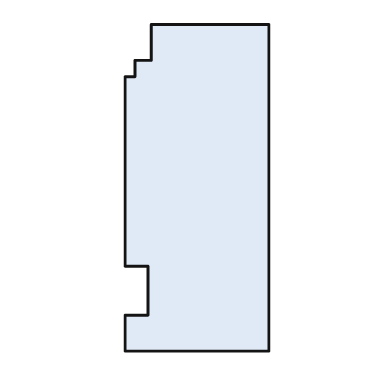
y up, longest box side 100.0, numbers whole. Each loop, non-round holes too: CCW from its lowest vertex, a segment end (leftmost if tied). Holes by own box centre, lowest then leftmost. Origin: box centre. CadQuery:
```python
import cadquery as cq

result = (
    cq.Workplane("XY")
    .moveTo(-22.0, -50.0)
    .lineTo(22.0, -50.0)
    .lineTo(22.0, 50.0)
    .lineTo(-14.0, 50.0)
    .lineTo(-14.0, 39.0)
    .lineTo(-19.0, 39.0)
    .lineTo(-19.0, 34.0)
    .lineTo(-22.0, 34.0)
    .lineTo(-22.0, -24.0)
    .lineTo(-15.0, -24.0)
    .lineTo(-15.0, -39.0)
    .lineTo(-22.0, -39.0)
    .close()
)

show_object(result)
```